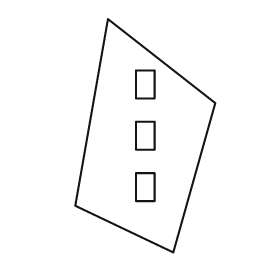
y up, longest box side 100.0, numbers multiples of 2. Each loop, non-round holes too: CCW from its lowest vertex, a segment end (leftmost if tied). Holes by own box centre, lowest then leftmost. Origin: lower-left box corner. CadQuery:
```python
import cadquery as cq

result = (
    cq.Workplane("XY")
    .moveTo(42.0, 0.0)
    .lineTo(60.0, 64.0)
    .lineTo(14.0, 100.0)
    .lineTo(0.0, 20.0)
    .close()
    .moveTo(26.0, 22.0)
    .lineTo(34.0, 22.0)
    .lineTo(34.0, 34.0)
    .lineTo(26.0, 34.0)
    .close()
    .moveTo(26.0, 44.0)
    .lineTo(34.0, 44.0)
    .lineTo(34.0, 56.0)
    .lineTo(26.0, 56.0)
    .close()
    .moveTo(26.0, 66.0)
    .lineTo(34.0, 66.0)
    .lineTo(34.0, 78.0)
    .lineTo(26.0, 78.0)
    .close()
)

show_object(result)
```